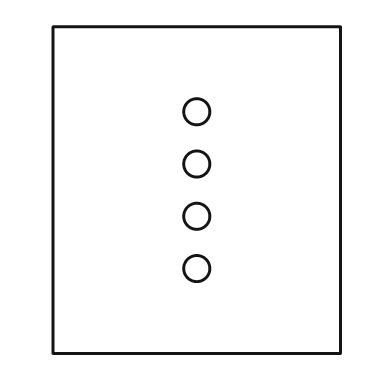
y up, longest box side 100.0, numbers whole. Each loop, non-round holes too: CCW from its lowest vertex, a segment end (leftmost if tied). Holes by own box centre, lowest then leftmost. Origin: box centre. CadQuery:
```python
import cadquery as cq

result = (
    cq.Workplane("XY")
    .moveTo(-44.0, -50.0)
    .lineTo(44.0, -50.0)
    .lineTo(44.0, 50.0)
    .lineTo(-44.0, 50.0)
    .close()
    .moveTo(0.0, -24.0)
    .circle(4.0)
    .moveTo(0.0, -8.0)
    .circle(4.0)
    .moveTo(0.0, 8.0)
    .circle(4.0)
    .moveTo(0.0, 24.0)
    .circle(4.0)
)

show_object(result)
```